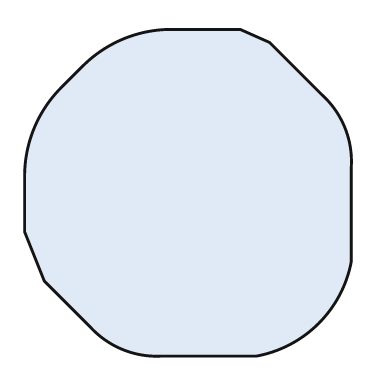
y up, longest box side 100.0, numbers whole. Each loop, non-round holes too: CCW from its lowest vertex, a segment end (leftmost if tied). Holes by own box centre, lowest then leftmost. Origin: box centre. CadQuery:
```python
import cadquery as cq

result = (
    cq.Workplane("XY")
    .moveTo(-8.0, -50.0)
    .lineTo(21.0, -50.0)
    .threePointArc((40.0, -40.0), (50.0, -21.0))
    .lineTo(50.0, 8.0)
    .threePointArc((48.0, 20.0), (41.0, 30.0))
    .lineTo(25.0, 46.0)
    .lineTo(16.0, 50.0)
    .lineTo(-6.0, 50.0)
    .threePointArc((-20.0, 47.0), (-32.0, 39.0))
    .lineTo(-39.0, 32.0)
    .threePointArc((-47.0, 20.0), (-50.0, 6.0))
    .lineTo(-50.0, -12.0)
    .lineTo(-44.0, -27.0)
    .lineTo(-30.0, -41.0)
    .threePointArc((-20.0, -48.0), (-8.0, -50.0))
    .close()
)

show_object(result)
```